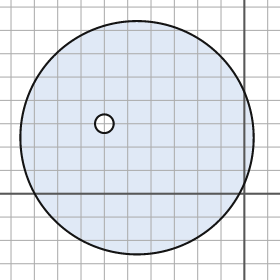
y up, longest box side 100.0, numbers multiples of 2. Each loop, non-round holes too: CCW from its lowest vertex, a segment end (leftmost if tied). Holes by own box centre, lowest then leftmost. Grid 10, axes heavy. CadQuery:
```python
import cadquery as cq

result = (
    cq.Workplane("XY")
    .moveTo(-46.0, 24.0)
    .circle(50.0)
    .moveTo(-60.0, 30.0)
    .circle(4.0)
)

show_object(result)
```